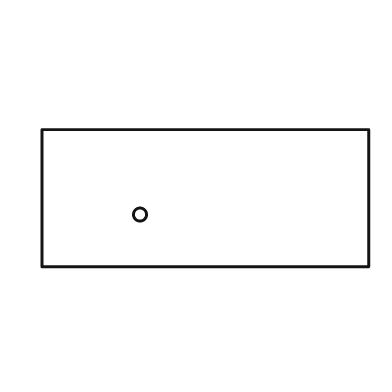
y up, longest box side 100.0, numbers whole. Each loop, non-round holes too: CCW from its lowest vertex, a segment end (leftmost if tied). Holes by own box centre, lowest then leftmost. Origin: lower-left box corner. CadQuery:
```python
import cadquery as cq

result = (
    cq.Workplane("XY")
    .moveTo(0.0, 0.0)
    .lineTo(100.0, 0.0)
    .lineTo(100.0, 42.0)
    .lineTo(0.0, 42.0)
    .close()
    .moveTo(30.0, 16.0)
    .circle(2.0)
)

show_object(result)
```